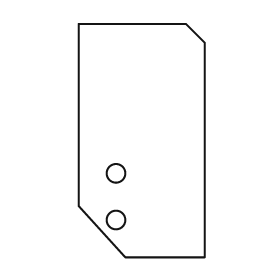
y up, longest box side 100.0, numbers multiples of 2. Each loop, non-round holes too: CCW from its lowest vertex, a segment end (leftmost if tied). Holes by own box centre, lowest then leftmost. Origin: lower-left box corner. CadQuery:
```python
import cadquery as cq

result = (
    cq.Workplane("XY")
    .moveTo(20.0, 0.0)
    .lineTo(54.0, 0.0)
    .lineTo(54.0, 92.0)
    .lineTo(46.0, 100.0)
    .lineTo(0.0, 100.0)
    .lineTo(0.0, 22.0)
    .close()
    .moveTo(16.0, 16.0)
    .circle(4.0)
    .moveTo(16.0, 36.0)
    .circle(4.0)
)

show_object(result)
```